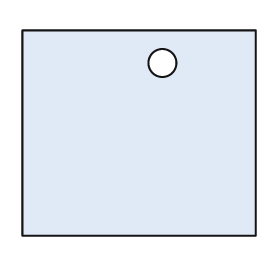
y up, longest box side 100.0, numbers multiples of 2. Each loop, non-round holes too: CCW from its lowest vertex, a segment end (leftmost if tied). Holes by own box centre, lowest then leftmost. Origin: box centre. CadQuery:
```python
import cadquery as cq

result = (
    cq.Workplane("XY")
    .moveTo(-50.0, -44.0)
    .lineTo(50.0, -44.0)
    .lineTo(50.0, 44.0)
    .lineTo(-50.0, 44.0)
    .close()
    .moveTo(10.0, 30.0)
    .circle(6.0)
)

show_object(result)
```